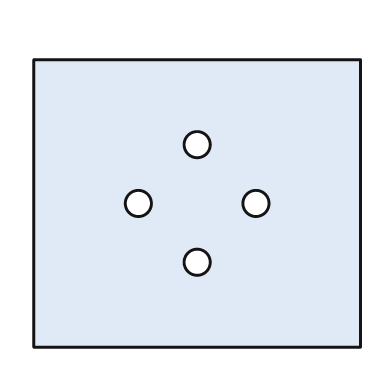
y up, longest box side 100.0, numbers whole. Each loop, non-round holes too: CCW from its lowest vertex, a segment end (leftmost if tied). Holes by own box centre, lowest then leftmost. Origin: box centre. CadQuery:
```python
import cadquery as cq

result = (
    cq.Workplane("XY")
    .moveTo(-50.0, -44.0)
    .lineTo(50.0, -44.0)
    .lineTo(50.0, 44.0)
    .lineTo(-50.0, 44.0)
    .close()
    .moveTo(0.0, -18.0)
    .circle(4.0)
    .moveTo(-18.0, 0.0)
    .circle(4.0)
    .moveTo(18.0, 0.0)
    .circle(4.0)
    .moveTo(0.0, 18.0)
    .circle(4.0)
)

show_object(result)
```